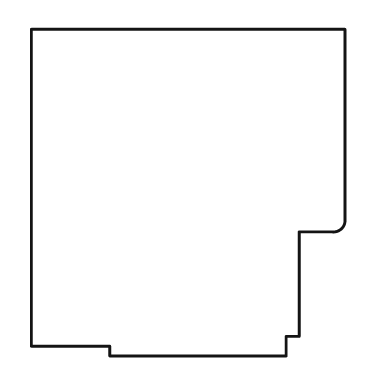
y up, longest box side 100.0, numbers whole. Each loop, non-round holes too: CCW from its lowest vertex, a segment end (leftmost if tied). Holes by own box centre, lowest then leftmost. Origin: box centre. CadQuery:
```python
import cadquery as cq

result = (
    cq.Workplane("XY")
    .moveTo(-24.0, -50.0)
    .lineTo(30.0, -50.0)
    .lineTo(30.0, -44.0)
    .lineTo(34.0, -44.0)
    .lineTo(34.0, -12.0)
    .lineTo(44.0, -12.0)
    .threePointArc((47.0, -11.0), (48.0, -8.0))
    .lineTo(48.0, 50.0)
    .lineTo(-48.0, 50.0)
    .lineTo(-48.0, -47.0)
    .lineTo(-24.0, -47.0)
    .close()
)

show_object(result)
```